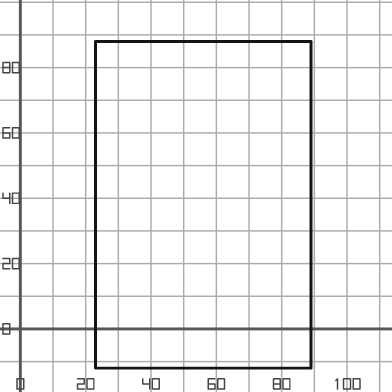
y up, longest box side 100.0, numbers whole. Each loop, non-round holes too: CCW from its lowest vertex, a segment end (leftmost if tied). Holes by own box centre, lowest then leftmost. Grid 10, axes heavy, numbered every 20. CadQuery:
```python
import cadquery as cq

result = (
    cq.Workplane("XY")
    .moveTo(23.0, -12.0)
    .lineTo(89.0, -12.0)
    .lineTo(89.0, 88.0)
    .lineTo(23.0, 88.0)
    .close()
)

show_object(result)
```